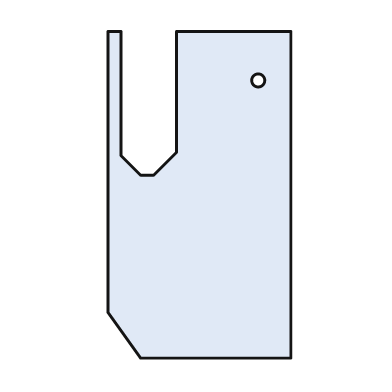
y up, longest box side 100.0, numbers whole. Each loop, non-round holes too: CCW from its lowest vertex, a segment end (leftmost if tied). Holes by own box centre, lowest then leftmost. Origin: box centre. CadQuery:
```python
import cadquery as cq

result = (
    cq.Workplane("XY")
    .moveTo(-18.0, -50.0)
    .lineTo(28.0, -50.0)
    .lineTo(28.0, 50.0)
    .lineTo(-7.0, 50.0)
    .lineTo(-7.0, 13.0)
    .lineTo(-14.0, 6.0)
    .lineTo(-18.0, 6.0)
    .lineTo(-24.0, 12.0)
    .lineTo(-24.0, 50.0)
    .lineTo(-28.0, 50.0)
    .lineTo(-28.0, -36.0)
    .close()
    .moveTo(18.0, 35.0)
    .circle(2.0)
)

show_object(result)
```